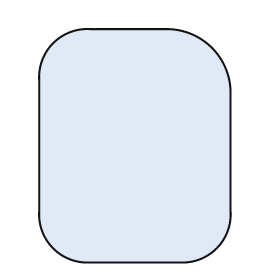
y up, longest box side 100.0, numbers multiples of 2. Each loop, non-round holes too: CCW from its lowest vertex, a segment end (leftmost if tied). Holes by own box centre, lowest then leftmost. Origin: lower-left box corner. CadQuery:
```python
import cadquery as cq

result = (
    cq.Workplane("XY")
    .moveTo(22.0, 0.0)
    .lineTo(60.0, 0.0)
    .threePointArc((76.0, 6.0), (82.0, 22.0))
    .lineTo(82.0, 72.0)
    .threePointArc((74.0, 92.0), (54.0, 100.0))
    .lineTo(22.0, 100.0)
    .threePointArc((6.0, 94.0), (0.0, 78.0))
    .lineTo(0.0, 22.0)
    .threePointArc((6.0, 6.0), (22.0, 0.0))
    .close()
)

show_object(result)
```